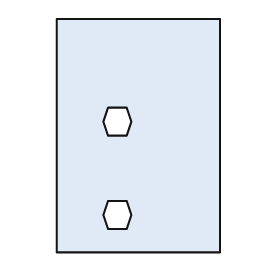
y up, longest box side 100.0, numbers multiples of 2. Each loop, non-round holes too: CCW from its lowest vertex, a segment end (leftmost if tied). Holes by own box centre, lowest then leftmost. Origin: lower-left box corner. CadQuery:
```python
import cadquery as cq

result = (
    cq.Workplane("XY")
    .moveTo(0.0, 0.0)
    .lineTo(70.0, 0.0)
    .lineTo(70.0, 100.0)
    .lineTo(0.0, 100.0)
    .close()
    .moveTo(22.0, 10.0)
    .lineTo(30.0, 10.0)
    .lineTo(32.0, 16.0)
    .lineTo(30.0, 22.0)
    .lineTo(22.0, 22.0)
    .lineTo(20.0, 16.0)
    .close()
    .moveTo(22.0, 50.0)
    .lineTo(30.0, 50.0)
    .lineTo(32.0, 56.0)
    .lineTo(30.0, 62.0)
    .lineTo(22.0, 62.0)
    .lineTo(20.0, 56.0)
    .close()
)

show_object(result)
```